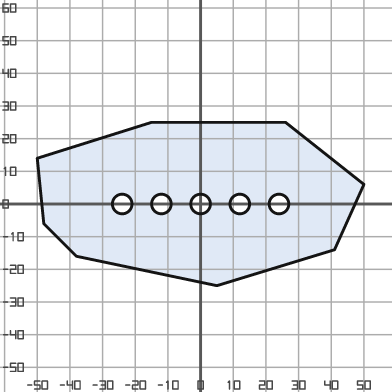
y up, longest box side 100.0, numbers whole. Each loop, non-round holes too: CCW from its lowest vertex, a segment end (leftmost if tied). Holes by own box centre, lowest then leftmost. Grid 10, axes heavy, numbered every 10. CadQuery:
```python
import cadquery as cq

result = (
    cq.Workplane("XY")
    .moveTo(5.0, -25.0)
    .lineTo(41.0, -14.0)
    .lineTo(50.0, 6.0)
    .lineTo(26.0, 25.0)
    .lineTo(-15.0, 25.0)
    .lineTo(-50.0, 14.0)
    .lineTo(-48.0, -6.0)
    .lineTo(-38.0, -16.0)
    .close()
    .moveTo(-24.0, 0.0)
    .circle(3.0)
    .moveTo(-12.0, 0.0)
    .circle(3.0)
    .moveTo(0.0, 0.0)
    .circle(3.0)
    .moveTo(12.0, 0.0)
    .circle(3.0)
    .moveTo(24.0, 0.0)
    .circle(3.0)
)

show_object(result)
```